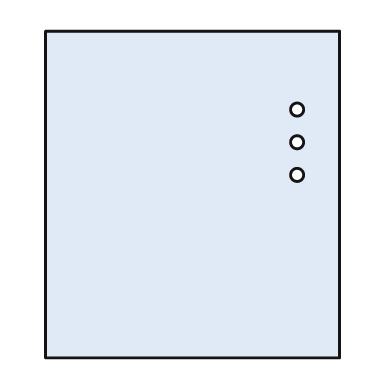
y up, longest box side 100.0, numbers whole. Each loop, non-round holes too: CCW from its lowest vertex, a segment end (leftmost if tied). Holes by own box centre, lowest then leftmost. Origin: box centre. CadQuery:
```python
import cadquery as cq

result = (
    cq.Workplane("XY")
    .moveTo(-45.0, -50.0)
    .lineTo(45.0, -50.0)
    .lineTo(45.0, 50.0)
    .lineTo(-45.0, 50.0)
    .close()
    .moveTo(32.0, 6.0)
    .circle(2.0)
    .moveTo(32.0, 16.0)
    .circle(2.0)
    .moveTo(32.0, 26.0)
    .circle(2.0)
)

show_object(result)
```